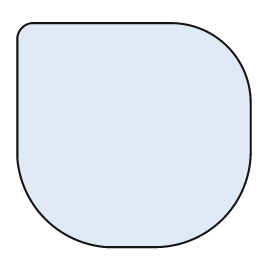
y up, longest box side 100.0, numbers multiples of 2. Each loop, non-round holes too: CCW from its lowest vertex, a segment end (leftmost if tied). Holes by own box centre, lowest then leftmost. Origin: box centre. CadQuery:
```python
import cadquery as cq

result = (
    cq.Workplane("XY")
    .moveTo(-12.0, -48.0)
    .lineTo(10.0, -48.0)
    .threePointArc((38.0, -36.0), (50.0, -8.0))
    .lineTo(50.0, 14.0)
    .threePointArc((40.0, 38.0), (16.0, 48.0))
    .lineTo(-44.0, 48.0)
    .threePointArc((-48.0, 46.0), (-50.0, 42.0))
    .lineTo(-50.0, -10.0)
    .threePointArc((-38.0, -36.0), (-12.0, -48.0))
    .close()
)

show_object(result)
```